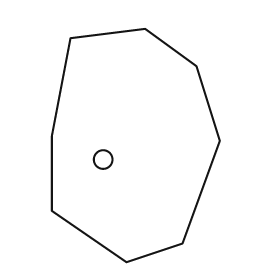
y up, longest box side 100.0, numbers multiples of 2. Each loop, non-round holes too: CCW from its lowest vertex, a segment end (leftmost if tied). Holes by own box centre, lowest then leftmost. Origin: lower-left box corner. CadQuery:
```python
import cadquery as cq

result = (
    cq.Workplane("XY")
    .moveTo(32.0, 0.0)
    .lineTo(56.0, 8.0)
    .lineTo(72.0, 52.0)
    .lineTo(62.0, 84.0)
    .lineTo(40.0, 100.0)
    .lineTo(8.0, 96.0)
    .lineTo(0.0, 54.0)
    .lineTo(0.0, 22.0)
    .close()
    .moveTo(22.0, 44.0)
    .circle(4.0)
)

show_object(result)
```